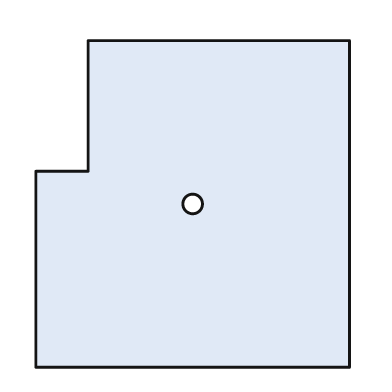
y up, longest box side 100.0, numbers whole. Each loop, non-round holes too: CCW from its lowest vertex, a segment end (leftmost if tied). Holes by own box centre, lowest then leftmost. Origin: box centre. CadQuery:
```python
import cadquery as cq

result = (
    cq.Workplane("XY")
    .moveTo(-48.0, -50.0)
    .lineTo(48.0, -50.0)
    .lineTo(48.0, 50.0)
    .lineTo(-32.0, 50.0)
    .lineTo(-32.0, 10.0)
    .lineTo(-48.0, 10.0)
    .close()
    .moveTo(0.0, 0.0)
    .circle(3.0)
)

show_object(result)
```